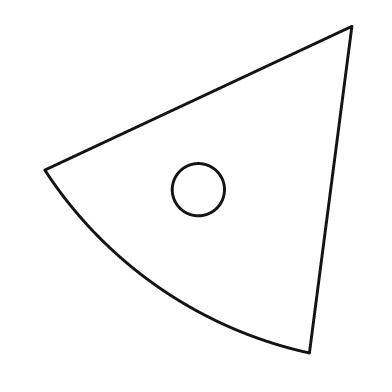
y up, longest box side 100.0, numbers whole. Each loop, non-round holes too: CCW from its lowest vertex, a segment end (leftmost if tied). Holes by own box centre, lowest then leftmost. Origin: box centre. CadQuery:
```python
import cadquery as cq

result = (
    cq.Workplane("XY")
    .moveTo(34.0, -50.0)
    .lineTo(47.0, 50.0)
    .lineTo(-47.0, 6.0)
    .threePointArc((-12.0, -30.0), (34.0, -50.0))
    .close()
    .moveTo(0.0, 0.0)
    .circle(8.0)
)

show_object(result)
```